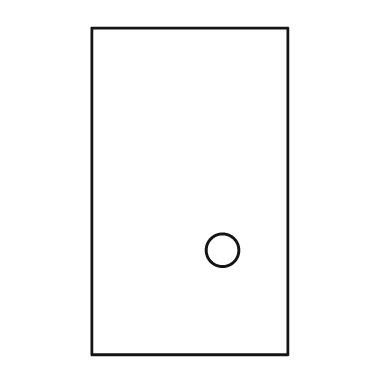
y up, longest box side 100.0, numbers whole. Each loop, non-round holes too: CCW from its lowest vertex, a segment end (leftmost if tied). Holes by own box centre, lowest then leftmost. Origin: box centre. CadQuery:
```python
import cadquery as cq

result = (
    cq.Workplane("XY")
    .moveTo(-30.0, -50.0)
    .lineTo(30.0, -50.0)
    .lineTo(30.0, 50.0)
    .lineTo(-30.0, 50.0)
    .close()
    .moveTo(10.0, -18.0)
    .circle(5.0)
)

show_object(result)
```